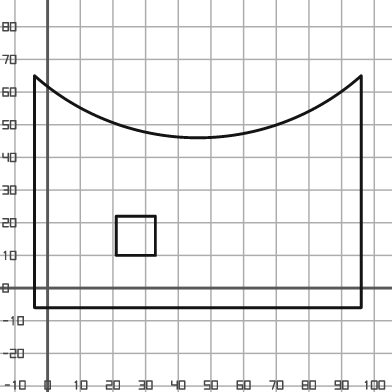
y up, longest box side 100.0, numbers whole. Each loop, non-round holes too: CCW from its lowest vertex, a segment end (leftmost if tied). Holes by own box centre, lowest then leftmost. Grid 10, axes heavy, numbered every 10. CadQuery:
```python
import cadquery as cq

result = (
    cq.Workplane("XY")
    .moveTo(-4.0, -6.0)
    .lineTo(96.0, -6.0)
    .lineTo(96.0, 65.0)
    .threePointArc((46.0, 46.0), (-4.0, 65.0))
    .close()
    .moveTo(21.0, 10.0)
    .lineTo(33.0, 10.0)
    .lineTo(33.0, 22.0)
    .lineTo(21.0, 22.0)
    .close()
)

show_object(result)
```